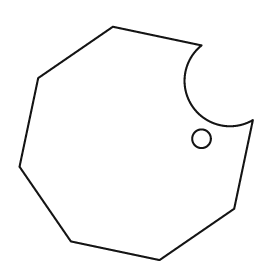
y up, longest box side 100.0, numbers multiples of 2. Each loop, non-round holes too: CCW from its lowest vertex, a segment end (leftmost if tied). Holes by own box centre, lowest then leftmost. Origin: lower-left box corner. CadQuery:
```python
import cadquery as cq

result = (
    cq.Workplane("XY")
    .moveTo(60.0, 0.0)
    .lineTo(92.0, 22.0)
    .lineTo(100.0, 60.0)
    .threePointArc((74.0, 66.0), (78.0, 92.0))
    .lineTo(40.0, 100.0)
    .lineTo(8.0, 78.0)
    .lineTo(0.0, 40.0)
    .lineTo(22.0, 8.0)
    .close()
    .moveTo(78.0, 52.0)
    .circle(4.0)
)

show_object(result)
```